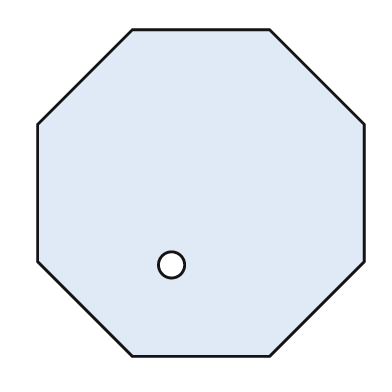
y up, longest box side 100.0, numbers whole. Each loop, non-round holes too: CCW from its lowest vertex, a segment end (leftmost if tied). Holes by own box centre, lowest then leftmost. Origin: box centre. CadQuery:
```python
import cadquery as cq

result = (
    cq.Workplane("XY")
    .moveTo(-21.0, -50.0)
    .lineTo(21.0, -50.0)
    .lineTo(50.0, -21.0)
    .lineTo(50.0, 21.0)
    .lineTo(21.0, 50.0)
    .lineTo(-21.0, 50.0)
    .lineTo(-50.0, 21.0)
    .lineTo(-50.0, -21.0)
    .close()
    .moveTo(-9.0, -22.0)
    .circle(4.0)
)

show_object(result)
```